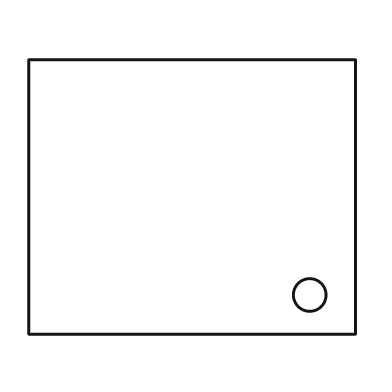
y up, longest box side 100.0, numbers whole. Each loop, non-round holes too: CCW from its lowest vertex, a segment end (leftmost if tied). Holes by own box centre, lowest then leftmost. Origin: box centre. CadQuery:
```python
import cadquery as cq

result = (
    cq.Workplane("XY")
    .moveTo(-50.0, -42.0)
    .lineTo(50.0, -42.0)
    .lineTo(50.0, 42.0)
    .lineTo(-50.0, 42.0)
    .close()
    .moveTo(36.0, -30.0)
    .circle(5.0)
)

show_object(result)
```